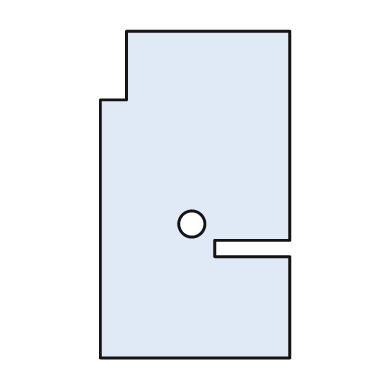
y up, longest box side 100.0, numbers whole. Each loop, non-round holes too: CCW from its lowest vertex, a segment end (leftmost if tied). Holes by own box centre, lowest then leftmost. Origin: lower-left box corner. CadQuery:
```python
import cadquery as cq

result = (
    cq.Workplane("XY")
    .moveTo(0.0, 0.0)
    .lineTo(58.0, 0.0)
    .lineTo(58.0, 31.0)
    .lineTo(35.0, 31.0)
    .lineTo(35.0, 36.0)
    .lineTo(58.0, 36.0)
    .lineTo(58.0, 100.0)
    .lineTo(8.0, 100.0)
    .lineTo(8.0, 79.0)
    .lineTo(0.0, 79.0)
    .close()
    .moveTo(28.0, 41.0)
    .circle(4.0)
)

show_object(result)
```